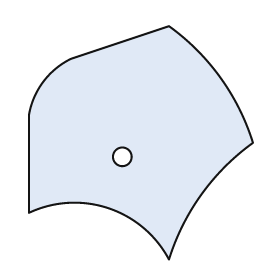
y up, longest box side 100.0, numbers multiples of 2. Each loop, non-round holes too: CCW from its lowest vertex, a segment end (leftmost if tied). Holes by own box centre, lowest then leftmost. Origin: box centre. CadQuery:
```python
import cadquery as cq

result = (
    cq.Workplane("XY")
    .moveTo(12.0, -50.0)
    .threePointArc((26.0, -22.0), (48.0, 0.0))
    .threePointArc((34.0, 28.0), (12.0, 50.0))
    .lineTo(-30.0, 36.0)
    .threePointArc((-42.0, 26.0), (-48.0, 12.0))
    .lineTo(-48.0, -30.0)
    .threePointArc((-14.0, -28.0), (12.0, -50.0))
    .close()
    .moveTo(-8.0, -6.0)
    .circle(4.0)
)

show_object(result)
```